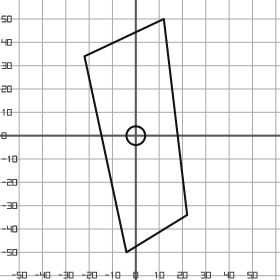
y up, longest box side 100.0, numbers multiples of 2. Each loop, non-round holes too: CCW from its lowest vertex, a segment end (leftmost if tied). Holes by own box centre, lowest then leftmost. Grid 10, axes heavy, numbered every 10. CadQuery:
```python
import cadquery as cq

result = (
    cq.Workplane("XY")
    .moveTo(-4.0, -50.0)
    .lineTo(22.0, -34.0)
    .lineTo(12.0, 50.0)
    .lineTo(-22.0, 34.0)
    .close()
    .moveTo(0.0, 0.0)
    .circle(4.0)
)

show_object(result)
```